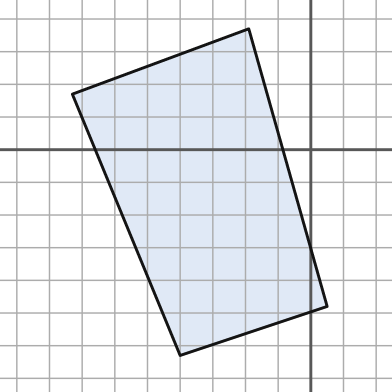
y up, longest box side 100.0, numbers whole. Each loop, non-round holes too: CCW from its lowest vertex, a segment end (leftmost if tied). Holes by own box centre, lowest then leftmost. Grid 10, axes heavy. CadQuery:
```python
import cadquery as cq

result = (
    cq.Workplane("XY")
    .moveTo(-40.0, -63.0)
    .lineTo(5.0, -48.0)
    .lineTo(-19.0, 37.0)
    .lineTo(-73.0, 17.0)
    .close()
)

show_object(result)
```